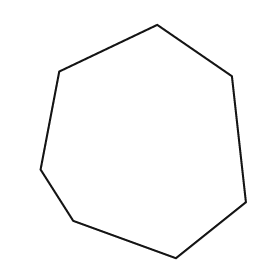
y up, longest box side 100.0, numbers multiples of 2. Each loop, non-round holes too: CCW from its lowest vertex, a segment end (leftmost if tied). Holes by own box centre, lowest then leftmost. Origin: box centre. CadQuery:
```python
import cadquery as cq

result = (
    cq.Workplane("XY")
    .moveTo(14.0, -50.0)
    .lineTo(44.0, -26.0)
    .lineTo(38.0, 28.0)
    .lineTo(6.0, 50.0)
    .lineTo(-36.0, 30.0)
    .lineTo(-44.0, -12.0)
    .lineTo(-30.0, -34.0)
    .close()
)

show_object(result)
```